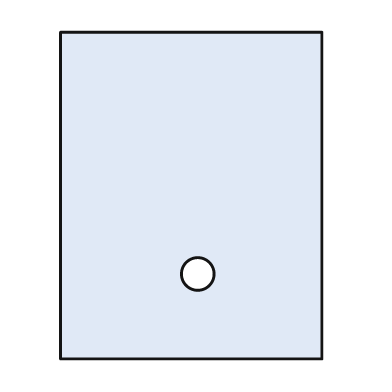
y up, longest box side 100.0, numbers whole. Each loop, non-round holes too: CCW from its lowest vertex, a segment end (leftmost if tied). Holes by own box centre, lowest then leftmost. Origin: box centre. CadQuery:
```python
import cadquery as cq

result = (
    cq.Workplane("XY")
    .moveTo(-40.0, -50.0)
    .lineTo(40.0, -50.0)
    .lineTo(40.0, 50.0)
    .lineTo(-40.0, 50.0)
    .close()
    .moveTo(2.0, -24.0)
    .circle(5.0)
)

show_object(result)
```